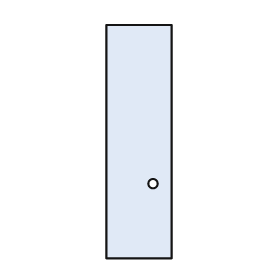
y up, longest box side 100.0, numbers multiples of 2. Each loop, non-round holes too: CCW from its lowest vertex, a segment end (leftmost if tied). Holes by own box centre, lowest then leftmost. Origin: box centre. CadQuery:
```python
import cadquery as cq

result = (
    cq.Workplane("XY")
    .moveTo(-14.0, -50.0)
    .lineTo(14.0, -50.0)
    .lineTo(14.0, 50.0)
    .lineTo(-14.0, 50.0)
    .close()
    .moveTo(6.0, -18.0)
    .circle(2.0)
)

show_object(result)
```